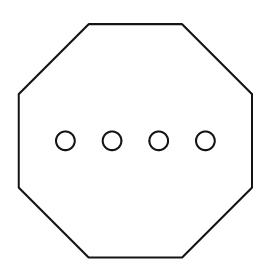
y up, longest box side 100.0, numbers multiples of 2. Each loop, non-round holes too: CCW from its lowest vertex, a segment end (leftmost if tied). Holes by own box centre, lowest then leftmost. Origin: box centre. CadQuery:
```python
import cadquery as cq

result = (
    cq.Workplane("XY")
    .moveTo(-20.0, -50.0)
    .lineTo(20.0, -50.0)
    .lineTo(50.0, -20.0)
    .lineTo(50.0, 20.0)
    .lineTo(20.0, 50.0)
    .lineTo(-20.0, 50.0)
    .lineTo(-50.0, 20.0)
    .lineTo(-50.0, -20.0)
    .close()
    .moveTo(-30.0, 0.0)
    .circle(4.0)
    .moveTo(-10.0, 0.0)
    .circle(4.0)
    .moveTo(10.0, 0.0)
    .circle(4.0)
    .moveTo(30.0, 0.0)
    .circle(4.0)
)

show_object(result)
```